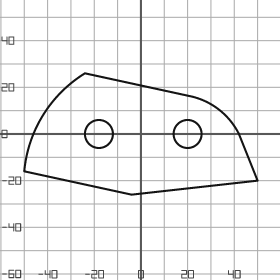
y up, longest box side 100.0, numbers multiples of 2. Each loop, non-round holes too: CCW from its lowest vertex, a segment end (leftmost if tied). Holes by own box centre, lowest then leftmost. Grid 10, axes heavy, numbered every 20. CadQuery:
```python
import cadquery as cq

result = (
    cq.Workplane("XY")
    .moveTo(-4.0, -26.0)
    .lineTo(50.0, -20.0)
    .lineTo(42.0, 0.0)
    .threePointArc((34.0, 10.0), (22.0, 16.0))
    .lineTo(-24.0, 26.0)
    .threePointArc((-42.0, 8.0), (-50.0, -16.0))
    .close()
    .moveTo(-18.0, 0.0)
    .circle(6.0)
    .moveTo(20.0, 0.0)
    .circle(6.0)
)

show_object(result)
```